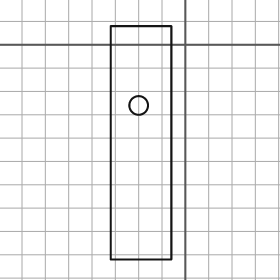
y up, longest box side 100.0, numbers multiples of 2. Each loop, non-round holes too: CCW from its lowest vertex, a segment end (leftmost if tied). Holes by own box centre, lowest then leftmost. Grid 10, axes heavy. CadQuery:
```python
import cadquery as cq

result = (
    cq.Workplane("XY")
    .moveTo(-32.0, -92.0)
    .lineTo(-6.0, -92.0)
    .lineTo(-6.0, 8.0)
    .lineTo(-32.0, 8.0)
    .close()
    .moveTo(-20.0, -26.0)
    .circle(4.0)
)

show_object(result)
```